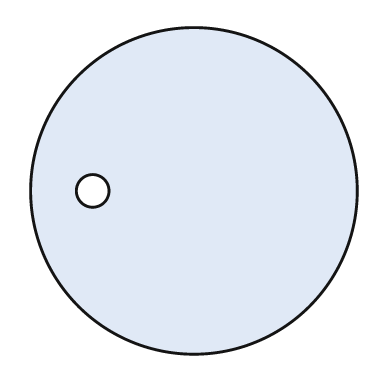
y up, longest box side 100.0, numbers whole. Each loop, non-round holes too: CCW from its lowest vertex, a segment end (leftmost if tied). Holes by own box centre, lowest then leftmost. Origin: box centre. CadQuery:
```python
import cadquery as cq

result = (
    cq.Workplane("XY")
    .moveTo(0.0, 0.0)
    .circle(50.0)
    .moveTo(-31.0, 0.0)
    .circle(5.0)
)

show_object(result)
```